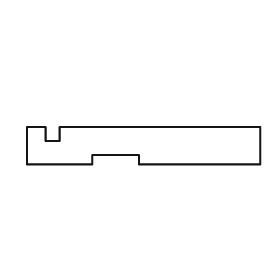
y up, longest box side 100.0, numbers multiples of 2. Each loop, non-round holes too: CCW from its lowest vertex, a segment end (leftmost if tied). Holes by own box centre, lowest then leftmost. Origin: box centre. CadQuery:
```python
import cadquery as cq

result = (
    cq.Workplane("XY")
    .moveTo(-50.0, -8.0)
    .lineTo(-22.0, -8.0)
    .lineTo(-22.0, -4.0)
    .lineTo(-2.0, -4.0)
    .lineTo(-2.0, -8.0)
    .lineTo(50.0, -8.0)
    .lineTo(50.0, 8.0)
    .lineTo(-36.0, 8.0)
    .lineTo(-36.0, 2.0)
    .lineTo(-42.0, 2.0)
    .lineTo(-42.0, 8.0)
    .lineTo(-50.0, 8.0)
    .close()
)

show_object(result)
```